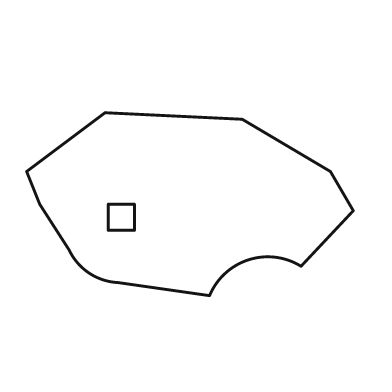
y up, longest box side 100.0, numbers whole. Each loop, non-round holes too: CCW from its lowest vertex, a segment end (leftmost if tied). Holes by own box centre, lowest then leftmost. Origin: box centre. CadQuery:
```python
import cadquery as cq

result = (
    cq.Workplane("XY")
    .moveTo(6.0, -28.0)
    .threePointArc((18.0, -17.0), (34.0, -19.0))
    .lineTo(50.0, -2.0)
    .lineTo(43.0, 10.0)
    .lineTo(16.0, 26.0)
    .lineTo(-26.0, 28.0)
    .lineTo(-50.0, 10.0)
    .lineTo(-46.0, 0.0)
    .lineTo(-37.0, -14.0)
    .threePointArc((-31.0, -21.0), (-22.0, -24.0))
    .close()
    .moveTo(-25.0, -8.0)
    .lineTo(-17.0, -8.0)
    .lineTo(-17.0, 0.0)
    .lineTo(-25.0, 0.0)
    .close()
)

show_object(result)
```